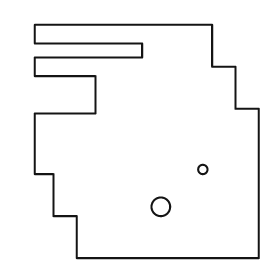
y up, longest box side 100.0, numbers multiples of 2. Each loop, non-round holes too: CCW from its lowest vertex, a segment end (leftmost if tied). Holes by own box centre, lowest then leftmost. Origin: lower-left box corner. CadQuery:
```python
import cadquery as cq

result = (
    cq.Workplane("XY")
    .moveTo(18.0, 0.0)
    .lineTo(96.0, 0.0)
    .lineTo(96.0, 64.0)
    .lineTo(86.0, 64.0)
    .lineTo(86.0, 82.0)
    .lineTo(76.0, 82.0)
    .lineTo(76.0, 100.0)
    .lineTo(0.0, 100.0)
    .lineTo(0.0, 92.0)
    .lineTo(46.0, 92.0)
    .lineTo(46.0, 86.0)
    .lineTo(0.0, 86.0)
    .lineTo(0.0, 78.0)
    .lineTo(26.0, 78.0)
    .lineTo(26.0, 62.0)
    .lineTo(0.0, 62.0)
    .lineTo(0.0, 36.0)
    .lineTo(8.0, 36.0)
    .lineTo(8.0, 18.0)
    .lineTo(18.0, 18.0)
    .close()
    .moveTo(54.0, 22.0)
    .circle(4.0)
    .moveTo(72.0, 38.0)
    .circle(2.0)
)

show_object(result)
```